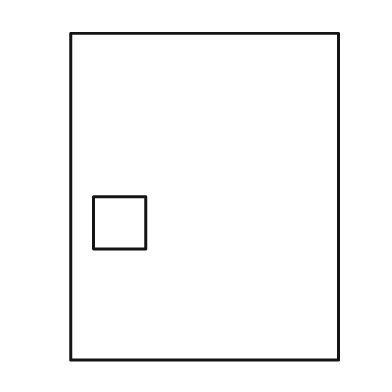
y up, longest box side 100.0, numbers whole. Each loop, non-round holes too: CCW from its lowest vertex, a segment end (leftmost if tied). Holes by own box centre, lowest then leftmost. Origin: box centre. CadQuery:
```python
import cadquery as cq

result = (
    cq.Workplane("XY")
    .moveTo(-41.0, -50.0)
    .lineTo(41.0, -50.0)
    .lineTo(41.0, 50.0)
    .lineTo(-41.0, 50.0)
    .close()
    .moveTo(-34.0, -16.0)
    .lineTo(-18.0, -16.0)
    .lineTo(-18.0, 0.0)
    .lineTo(-34.0, 0.0)
    .close()
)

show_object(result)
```